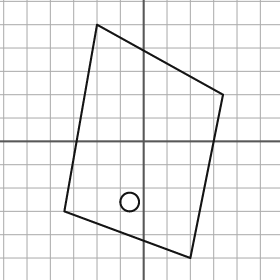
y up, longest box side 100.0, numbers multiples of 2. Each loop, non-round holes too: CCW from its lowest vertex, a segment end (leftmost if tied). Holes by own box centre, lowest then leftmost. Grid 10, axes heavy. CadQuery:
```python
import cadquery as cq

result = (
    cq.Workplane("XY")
    .moveTo(20.0, -50.0)
    .lineTo(34.0, 20.0)
    .lineTo(-20.0, 50.0)
    .lineTo(-34.0, -30.0)
    .close()
    .moveTo(-6.0, -26.0)
    .circle(4.0)
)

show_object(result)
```